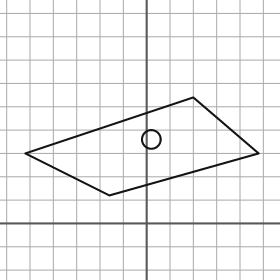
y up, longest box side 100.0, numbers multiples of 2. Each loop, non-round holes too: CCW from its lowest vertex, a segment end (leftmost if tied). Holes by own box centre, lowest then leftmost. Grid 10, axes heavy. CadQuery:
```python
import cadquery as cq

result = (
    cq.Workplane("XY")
    .moveTo(-16.0, 12.0)
    .lineTo(48.0, 30.0)
    .lineTo(20.0, 54.0)
    .lineTo(-52.0, 30.0)
    .close()
    .moveTo(2.0, 36.0)
    .circle(4.0)
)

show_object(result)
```